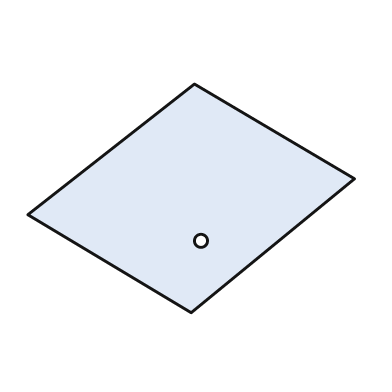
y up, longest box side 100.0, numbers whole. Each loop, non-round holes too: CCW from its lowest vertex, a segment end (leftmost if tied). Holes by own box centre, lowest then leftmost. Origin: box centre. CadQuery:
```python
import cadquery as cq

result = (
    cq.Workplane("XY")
    .moveTo(0.0, -35.0)
    .lineTo(50.0, 6.0)
    .lineTo(1.0, 35.0)
    .lineTo(-50.0, -5.0)
    .close()
    .moveTo(3.0, -13.0)
    .circle(2.0)
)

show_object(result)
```